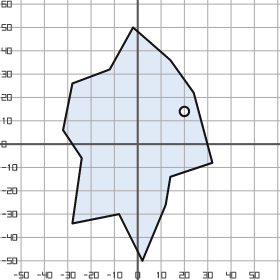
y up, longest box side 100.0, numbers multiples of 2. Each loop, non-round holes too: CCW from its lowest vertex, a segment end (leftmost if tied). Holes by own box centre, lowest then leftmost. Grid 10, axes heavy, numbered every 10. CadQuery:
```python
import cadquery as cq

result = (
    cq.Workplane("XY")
    .moveTo(2.0, -50.0)
    .lineTo(12.0, -26.0)
    .lineTo(14.0, -14.0)
    .lineTo(32.0, -8.0)
    .lineTo(24.0, 22.0)
    .lineTo(14.0, 36.0)
    .lineTo(-2.0, 50.0)
    .lineTo(-12.0, 32.0)
    .lineTo(-28.0, 26.0)
    .lineTo(-32.0, 6.0)
    .lineTo(-24.0, -6.0)
    .lineTo(-28.0, -34.0)
    .lineTo(-8.0, -30.0)
    .close()
    .moveTo(20.0, 14.0)
    .circle(2.0)
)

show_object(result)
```